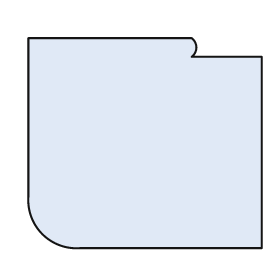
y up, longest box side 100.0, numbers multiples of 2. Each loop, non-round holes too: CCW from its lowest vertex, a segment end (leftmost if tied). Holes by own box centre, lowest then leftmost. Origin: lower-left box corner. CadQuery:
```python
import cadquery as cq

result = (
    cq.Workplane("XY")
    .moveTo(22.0, 0.0)
    .lineTo(100.0, 0.0)
    .lineTo(100.0, 82.0)
    .lineTo(70.0, 82.0)
    .threePointArc((72.0, 86.0), (70.0, 90.0))
    .lineTo(0.0, 90.0)
    .lineTo(0.0, 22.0)
    .threePointArc((6.0, 6.0), (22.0, 0.0))
    .close()
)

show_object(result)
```